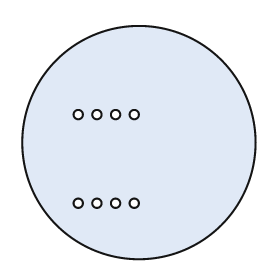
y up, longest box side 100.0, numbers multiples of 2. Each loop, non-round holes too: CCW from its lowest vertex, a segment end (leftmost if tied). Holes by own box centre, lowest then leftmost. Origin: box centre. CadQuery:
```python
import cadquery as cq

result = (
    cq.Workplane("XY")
    .moveTo(0.0, 0.0)
    .circle(50.0)
    .moveTo(-26.0, -26.0)
    .circle(2.0)
    .moveTo(-18.0, -26.0)
    .circle(2.0)
    .moveTo(-10.0, -26.0)
    .circle(2.0)
    .moveTo(-2.0, -26.0)
    .circle(2.0)
    .moveTo(-26.0, 12.0)
    .circle(2.0)
    .moveTo(-18.0, 12.0)
    .circle(2.0)
    .moveTo(-10.0, 12.0)
    .circle(2.0)
    .moveTo(-2.0, 12.0)
    .circle(2.0)
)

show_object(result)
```